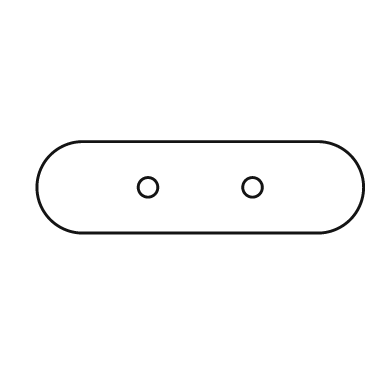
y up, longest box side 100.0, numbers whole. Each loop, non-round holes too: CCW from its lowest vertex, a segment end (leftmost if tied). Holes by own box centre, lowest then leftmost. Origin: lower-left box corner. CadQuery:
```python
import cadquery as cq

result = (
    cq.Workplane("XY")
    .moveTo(14.0, 0.0)
    .lineTo(86.0, 0.0)
    .threePointArc((100.0, 14.0), (86.0, 28.0))
    .lineTo(14.0, 28.0)
    .threePointArc((0.0, 14.0), (14.0, 0.0))
    .close()
    .moveTo(34.0, 14.0)
    .circle(3.0)
    .moveTo(66.0, 14.0)
    .circle(3.0)
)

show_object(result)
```